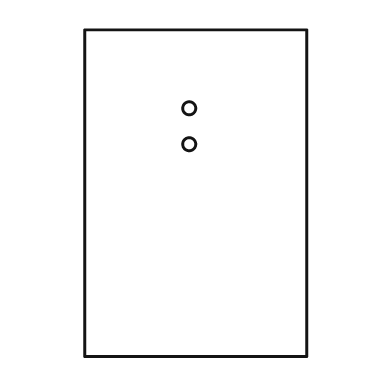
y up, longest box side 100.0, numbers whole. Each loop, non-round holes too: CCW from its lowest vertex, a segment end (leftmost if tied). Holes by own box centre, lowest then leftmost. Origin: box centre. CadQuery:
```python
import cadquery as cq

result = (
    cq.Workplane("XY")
    .moveTo(-34.0, -50.0)
    .lineTo(34.0, -50.0)
    .lineTo(34.0, 50.0)
    .lineTo(-34.0, 50.0)
    .close()
    .moveTo(-2.0, 15.0)
    .circle(2.0)
    .moveTo(-2.0, 26.0)
    .circle(2.0)
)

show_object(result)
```